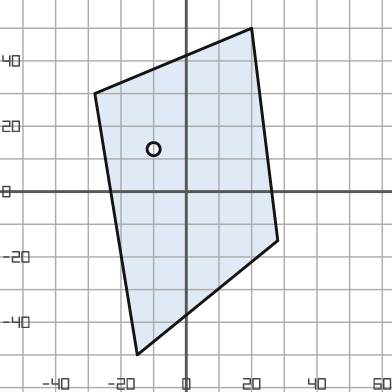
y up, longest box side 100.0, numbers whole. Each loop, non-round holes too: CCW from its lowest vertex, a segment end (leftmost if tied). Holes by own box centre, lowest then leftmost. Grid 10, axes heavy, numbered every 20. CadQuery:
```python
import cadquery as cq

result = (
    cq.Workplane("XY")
    .moveTo(-15.0, -50.0)
    .lineTo(28.0, -15.0)
    .lineTo(20.0, 50.0)
    .lineTo(-28.0, 30.0)
    .close()
    .moveTo(-10.0, 13.0)
    .circle(2.0)
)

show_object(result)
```